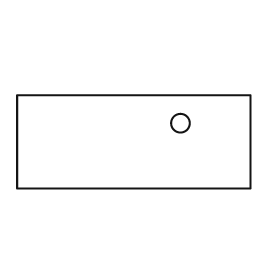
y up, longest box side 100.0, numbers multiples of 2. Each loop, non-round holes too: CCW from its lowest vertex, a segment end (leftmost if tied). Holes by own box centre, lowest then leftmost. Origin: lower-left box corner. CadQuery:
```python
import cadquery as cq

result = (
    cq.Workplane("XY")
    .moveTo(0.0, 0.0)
    .lineTo(100.0, 0.0)
    .lineTo(100.0, 40.0)
    .lineTo(0.0, 40.0)
    .close()
    .moveTo(70.0, 28.0)
    .circle(4.0)
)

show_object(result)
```